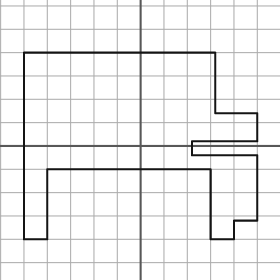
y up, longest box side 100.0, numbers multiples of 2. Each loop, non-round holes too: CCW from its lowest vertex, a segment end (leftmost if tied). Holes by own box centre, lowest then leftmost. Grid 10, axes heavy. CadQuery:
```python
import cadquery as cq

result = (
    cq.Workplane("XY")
    .moveTo(-50.0, -40.0)
    .lineTo(-40.0, -40.0)
    .lineTo(-40.0, -10.0)
    .lineTo(30.0, -10.0)
    .lineTo(30.0, -40.0)
    .lineTo(40.0, -40.0)
    .lineTo(40.0, -32.0)
    .lineTo(50.0, -32.0)
    .lineTo(50.0, -4.0)
    .lineTo(22.0, -4.0)
    .lineTo(22.0, 2.0)
    .lineTo(50.0, 2.0)
    .lineTo(50.0, 14.0)
    .lineTo(32.0, 14.0)
    .lineTo(32.0, 40.0)
    .lineTo(-50.0, 40.0)
    .close()
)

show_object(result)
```